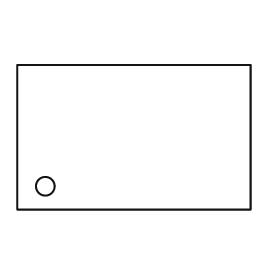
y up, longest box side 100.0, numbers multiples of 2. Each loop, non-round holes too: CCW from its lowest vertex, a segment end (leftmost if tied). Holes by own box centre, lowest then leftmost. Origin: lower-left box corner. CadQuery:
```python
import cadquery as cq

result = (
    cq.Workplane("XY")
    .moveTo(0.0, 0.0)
    .lineTo(100.0, 0.0)
    .lineTo(100.0, 62.0)
    .lineTo(0.0, 62.0)
    .close()
    .moveTo(12.0, 10.0)
    .circle(4.0)
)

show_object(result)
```